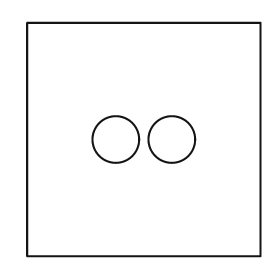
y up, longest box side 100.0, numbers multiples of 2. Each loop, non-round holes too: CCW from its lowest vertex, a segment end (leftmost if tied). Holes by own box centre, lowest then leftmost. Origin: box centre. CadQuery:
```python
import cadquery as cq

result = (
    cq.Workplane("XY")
    .moveTo(-50.0, -50.0)
    .lineTo(50.0, -50.0)
    .lineTo(50.0, 50.0)
    .lineTo(-50.0, 50.0)
    .close()
    .moveTo(-12.0, 0.0)
    .circle(10.0)
    .moveTo(12.0, 0.0)
    .circle(10.0)
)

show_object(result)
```